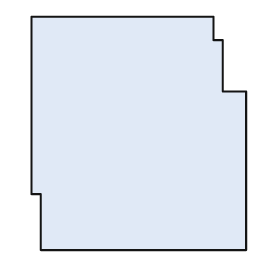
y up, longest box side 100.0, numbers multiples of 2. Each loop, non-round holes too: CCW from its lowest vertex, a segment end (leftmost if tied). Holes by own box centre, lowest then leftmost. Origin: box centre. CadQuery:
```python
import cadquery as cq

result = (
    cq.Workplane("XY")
    .moveTo(-42.0, -50.0)
    .lineTo(46.0, -50.0)
    .lineTo(46.0, 18.0)
    .lineTo(36.0, 18.0)
    .lineTo(36.0, 40.0)
    .lineTo(32.0, 40.0)
    .lineTo(32.0, 50.0)
    .lineTo(-46.0, 50.0)
    .lineTo(-46.0, -26.0)
    .lineTo(-42.0, -26.0)
    .close()
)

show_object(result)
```